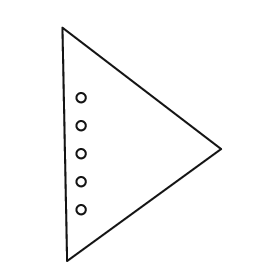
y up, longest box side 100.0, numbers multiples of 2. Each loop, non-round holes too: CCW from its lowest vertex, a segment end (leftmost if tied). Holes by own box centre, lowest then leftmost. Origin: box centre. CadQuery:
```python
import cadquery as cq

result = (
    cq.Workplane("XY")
    .moveTo(-32.0, -50.0)
    .lineTo(34.0, -2.0)
    .lineTo(-34.0, 50.0)
    .close()
    .moveTo(-26.0, -28.0)
    .circle(2.0)
    .moveTo(-26.0, -16.0)
    .circle(2.0)
    .moveTo(-26.0, -4.0)
    .circle(2.0)
    .moveTo(-26.0, 8.0)
    .circle(2.0)
    .moveTo(-26.0, 20.0)
    .circle(2.0)
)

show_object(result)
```